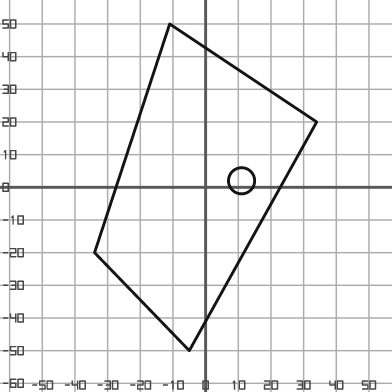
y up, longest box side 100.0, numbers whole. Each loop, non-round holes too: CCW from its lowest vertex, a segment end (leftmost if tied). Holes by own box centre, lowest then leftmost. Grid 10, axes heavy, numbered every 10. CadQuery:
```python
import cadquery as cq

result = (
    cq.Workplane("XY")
    .moveTo(-5.0, -50.0)
    .lineTo(34.0, 20.0)
    .lineTo(-11.0, 50.0)
    .lineTo(-34.0, -20.0)
    .close()
    .moveTo(11.0, 2.0)
    .circle(4.0)
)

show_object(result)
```